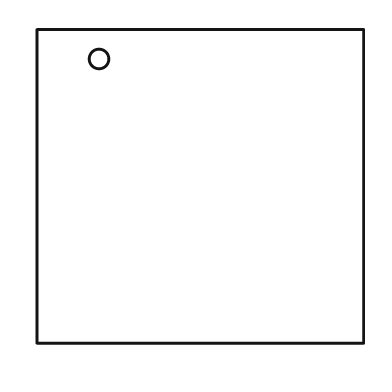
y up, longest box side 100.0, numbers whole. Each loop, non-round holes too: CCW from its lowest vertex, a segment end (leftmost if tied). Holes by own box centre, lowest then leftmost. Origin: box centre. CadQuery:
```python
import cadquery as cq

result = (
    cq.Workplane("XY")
    .moveTo(-50.0, -48.0)
    .lineTo(50.0, -48.0)
    .lineTo(50.0, 48.0)
    .lineTo(-50.0, 48.0)
    .close()
    .moveTo(-31.0, 39.0)
    .circle(3.0)
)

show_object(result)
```